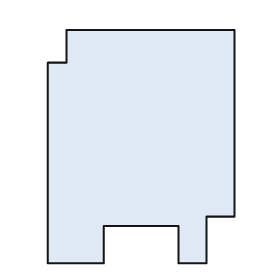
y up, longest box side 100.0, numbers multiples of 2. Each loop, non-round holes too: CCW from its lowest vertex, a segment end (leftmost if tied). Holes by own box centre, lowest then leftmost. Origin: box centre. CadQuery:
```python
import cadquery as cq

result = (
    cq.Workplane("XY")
    .moveTo(-40.0, -50.0)
    .lineTo(-16.0, -50.0)
    .lineTo(-16.0, -34.0)
    .lineTo(16.0, -34.0)
    .lineTo(16.0, -50.0)
    .lineTo(28.0, -50.0)
    .lineTo(28.0, -30.0)
    .lineTo(40.0, -30.0)
    .lineTo(40.0, 50.0)
    .lineTo(-32.0, 50.0)
    .lineTo(-32.0, 36.0)
    .lineTo(-40.0, 36.0)
    .close()
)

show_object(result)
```